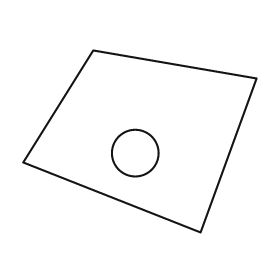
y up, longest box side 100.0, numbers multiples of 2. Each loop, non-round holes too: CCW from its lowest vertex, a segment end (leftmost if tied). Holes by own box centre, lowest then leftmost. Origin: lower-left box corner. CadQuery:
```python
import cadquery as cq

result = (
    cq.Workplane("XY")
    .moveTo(76.0, 0.0)
    .lineTo(100.0, 66.0)
    .lineTo(30.0, 78.0)
    .lineTo(0.0, 30.0)
    .close()
    .moveTo(48.0, 34.0)
    .circle(10.0)
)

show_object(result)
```